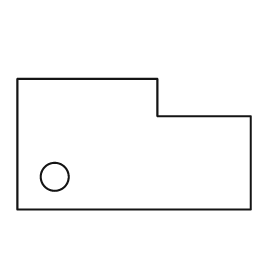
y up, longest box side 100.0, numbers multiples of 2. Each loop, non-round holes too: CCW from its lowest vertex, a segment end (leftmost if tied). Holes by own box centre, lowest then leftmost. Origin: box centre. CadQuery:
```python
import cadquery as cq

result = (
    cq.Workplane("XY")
    .moveTo(-50.0, -28.0)
    .lineTo(50.0, -28.0)
    .lineTo(50.0, 12.0)
    .lineTo(10.0, 12.0)
    .lineTo(10.0, 28.0)
    .lineTo(-50.0, 28.0)
    .close()
    .moveTo(-34.0, -14.0)
    .circle(6.0)
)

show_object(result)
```